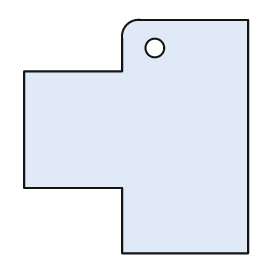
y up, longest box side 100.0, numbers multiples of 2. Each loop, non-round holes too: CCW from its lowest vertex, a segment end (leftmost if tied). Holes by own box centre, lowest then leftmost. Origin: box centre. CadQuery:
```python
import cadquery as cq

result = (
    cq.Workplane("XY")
    .moveTo(-6.0, -50.0)
    .lineTo(48.0, -50.0)
    .lineTo(48.0, 50.0)
    .lineTo(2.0, 50.0)
    .threePointArc((-4.0, 48.0), (-6.0, 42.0))
    .lineTo(-6.0, 28.0)
    .lineTo(-48.0, 28.0)
    .lineTo(-48.0, -22.0)
    .lineTo(-6.0, -22.0)
    .close()
    .moveTo(8.0, 38.0)
    .circle(4.0)
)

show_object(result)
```